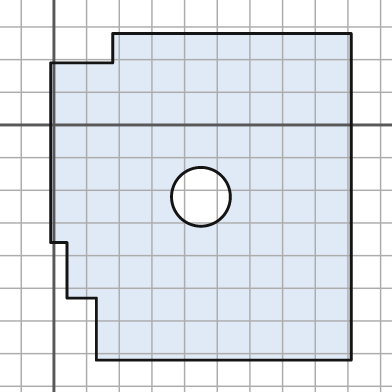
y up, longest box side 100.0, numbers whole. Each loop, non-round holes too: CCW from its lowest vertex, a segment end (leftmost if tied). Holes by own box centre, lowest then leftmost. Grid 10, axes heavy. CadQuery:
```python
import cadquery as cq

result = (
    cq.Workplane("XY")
    .moveTo(13.0, -72.0)
    .lineTo(91.0, -72.0)
    .lineTo(91.0, 28.0)
    .lineTo(18.0, 28.0)
    .lineTo(18.0, 19.0)
    .lineTo(-1.0, 19.0)
    .lineTo(-1.0, -36.0)
    .lineTo(4.0, -36.0)
    .lineTo(4.0, -53.0)
    .lineTo(13.0, -53.0)
    .close()
    .moveTo(45.0, -22.0)
    .circle(9.0)
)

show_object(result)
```